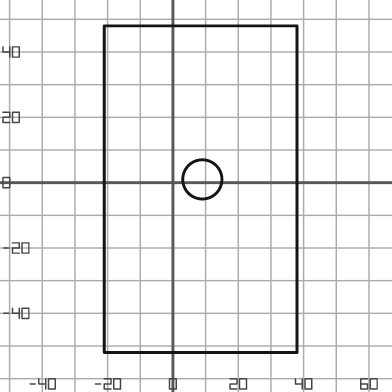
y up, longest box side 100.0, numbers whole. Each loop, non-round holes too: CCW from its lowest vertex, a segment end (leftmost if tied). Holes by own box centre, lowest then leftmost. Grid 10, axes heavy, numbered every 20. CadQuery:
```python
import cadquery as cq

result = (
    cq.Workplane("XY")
    .moveTo(-21.0, -52.0)
    .lineTo(38.0, -52.0)
    .lineTo(38.0, 48.0)
    .lineTo(-21.0, 48.0)
    .close()
    .moveTo(9.0, 1.0)
    .circle(6.0)
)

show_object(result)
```